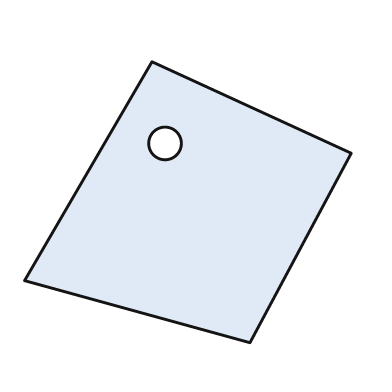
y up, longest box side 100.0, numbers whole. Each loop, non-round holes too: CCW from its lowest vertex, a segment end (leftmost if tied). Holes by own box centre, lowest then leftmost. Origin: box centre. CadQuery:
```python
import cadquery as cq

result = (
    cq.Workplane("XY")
    .moveTo(19.0, -43.0)
    .lineTo(50.0, 15.0)
    .lineTo(-11.0, 43.0)
    .lineTo(-50.0, -24.0)
    .close()
    .moveTo(-7.0, 18.0)
    .circle(5.0)
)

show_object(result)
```